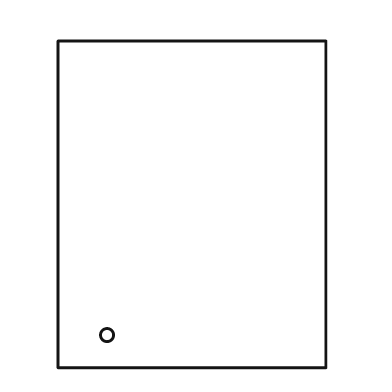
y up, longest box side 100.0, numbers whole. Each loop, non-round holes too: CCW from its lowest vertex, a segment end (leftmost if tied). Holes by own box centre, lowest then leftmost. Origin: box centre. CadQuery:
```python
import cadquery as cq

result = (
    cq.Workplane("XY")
    .moveTo(-41.0, -50.0)
    .lineTo(41.0, -50.0)
    .lineTo(41.0, 50.0)
    .lineTo(-41.0, 50.0)
    .close()
    .moveTo(-26.0, -40.0)
    .circle(2.0)
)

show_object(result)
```